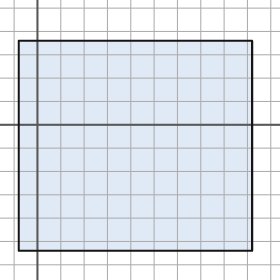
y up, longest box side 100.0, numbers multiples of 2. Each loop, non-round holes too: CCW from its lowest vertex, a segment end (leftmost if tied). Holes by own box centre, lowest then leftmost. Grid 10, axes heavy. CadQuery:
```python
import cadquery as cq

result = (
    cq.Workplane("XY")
    .moveTo(-8.0, -54.0)
    .lineTo(92.0, -54.0)
    .lineTo(92.0, 36.0)
    .lineTo(-8.0, 36.0)
    .close()
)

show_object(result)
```